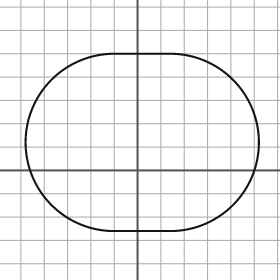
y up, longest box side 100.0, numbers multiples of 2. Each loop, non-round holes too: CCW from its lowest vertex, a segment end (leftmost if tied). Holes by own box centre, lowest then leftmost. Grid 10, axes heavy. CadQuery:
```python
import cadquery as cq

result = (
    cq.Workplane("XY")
    .moveTo(-10.0, -26.0)
    .lineTo(14.0, -26.0)
    .threePointArc((52.0, 12.0), (14.0, 50.0))
    .lineTo(-10.0, 50.0)
    .threePointArc((-48.0, 12.0), (-10.0, -26.0))
    .close()
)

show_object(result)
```